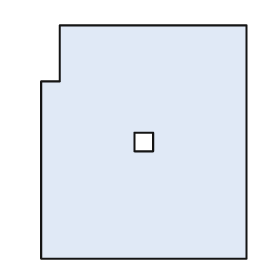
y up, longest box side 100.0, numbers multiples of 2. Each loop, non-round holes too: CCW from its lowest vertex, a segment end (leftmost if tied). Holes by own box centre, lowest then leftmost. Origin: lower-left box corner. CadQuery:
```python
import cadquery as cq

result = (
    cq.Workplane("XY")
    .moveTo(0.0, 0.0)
    .lineTo(88.0, 0.0)
    .lineTo(88.0, 100.0)
    .lineTo(8.0, 100.0)
    .lineTo(8.0, 76.0)
    .lineTo(0.0, 76.0)
    .close()
    .moveTo(40.0, 46.0)
    .lineTo(48.0, 46.0)
    .lineTo(48.0, 54.0)
    .lineTo(40.0, 54.0)
    .close()
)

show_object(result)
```